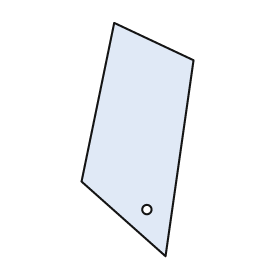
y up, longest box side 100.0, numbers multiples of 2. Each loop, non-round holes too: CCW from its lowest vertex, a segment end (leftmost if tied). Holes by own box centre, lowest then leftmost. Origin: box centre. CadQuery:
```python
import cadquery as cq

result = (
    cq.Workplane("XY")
    .moveTo(12.0, -50.0)
    .lineTo(24.0, 34.0)
    .lineTo(-10.0, 50.0)
    .lineTo(-24.0, -18.0)
    .close()
    .moveTo(4.0, -30.0)
    .circle(2.0)
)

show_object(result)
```